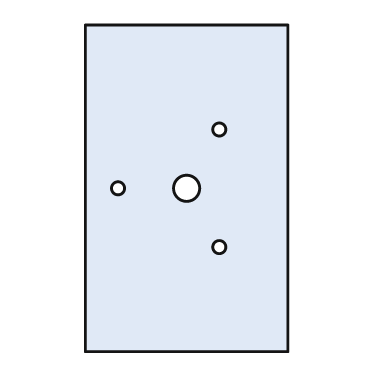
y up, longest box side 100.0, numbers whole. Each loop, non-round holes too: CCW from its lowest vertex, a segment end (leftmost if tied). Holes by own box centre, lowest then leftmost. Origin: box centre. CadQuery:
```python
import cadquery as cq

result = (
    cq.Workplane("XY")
    .moveTo(-31.0, -50.0)
    .lineTo(31.0, -50.0)
    .lineTo(31.0, 50.0)
    .lineTo(-31.0, 50.0)
    .close()
    .moveTo(10.0, -18.0)
    .circle(2.0)
    .moveTo(-21.0, 0.0)
    .circle(2.0)
    .moveTo(0.0, 0.0)
    .circle(4.0)
    .moveTo(10.0, 18.0)
    .circle(2.0)
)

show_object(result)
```